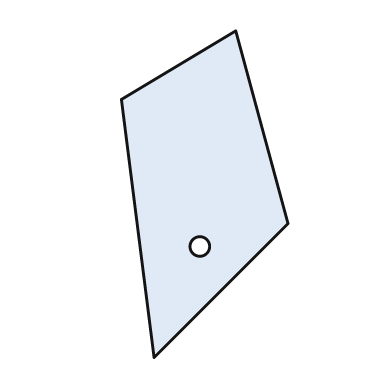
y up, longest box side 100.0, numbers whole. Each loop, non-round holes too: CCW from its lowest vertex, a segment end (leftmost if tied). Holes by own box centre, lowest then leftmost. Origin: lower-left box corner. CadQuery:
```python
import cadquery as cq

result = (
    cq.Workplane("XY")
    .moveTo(10.0, 0.0)
    .lineTo(51.0, 41.0)
    .lineTo(35.0, 100.0)
    .lineTo(0.0, 79.0)
    .close()
    .moveTo(24.0, 34.0)
    .circle(3.0)
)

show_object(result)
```